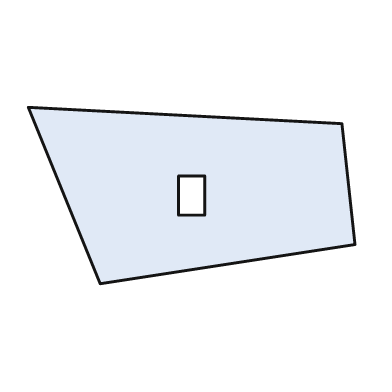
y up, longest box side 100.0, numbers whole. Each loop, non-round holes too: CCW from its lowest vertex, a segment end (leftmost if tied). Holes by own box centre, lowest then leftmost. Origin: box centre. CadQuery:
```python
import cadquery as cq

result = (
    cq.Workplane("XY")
    .moveTo(-28.0, -27.0)
    .lineTo(50.0, -15.0)
    .lineTo(46.0, 22.0)
    .lineTo(-50.0, 27.0)
    .close()
    .moveTo(-4.0, -6.0)
    .lineTo(4.0, -6.0)
    .lineTo(4.0, 6.0)
    .lineTo(-4.0, 6.0)
    .close()
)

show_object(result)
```